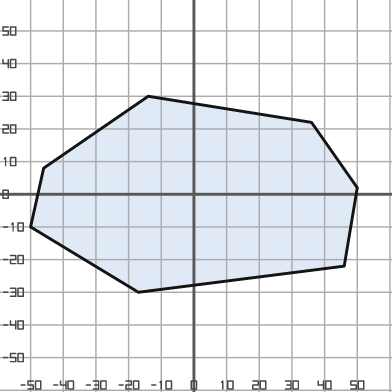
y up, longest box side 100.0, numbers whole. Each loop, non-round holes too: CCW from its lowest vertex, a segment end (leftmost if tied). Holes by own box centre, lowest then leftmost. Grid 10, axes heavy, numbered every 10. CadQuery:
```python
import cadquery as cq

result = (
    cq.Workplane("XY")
    .moveTo(-17.0, -30.0)
    .lineTo(46.0, -22.0)
    .lineTo(50.0, 2.0)
    .lineTo(36.0, 22.0)
    .lineTo(-14.0, 30.0)
    .lineTo(-46.0, 8.0)
    .lineTo(-50.0, -10.0)
    .close()
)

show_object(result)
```